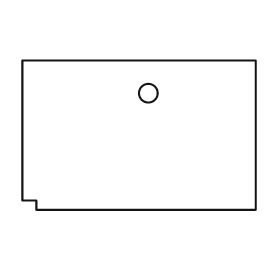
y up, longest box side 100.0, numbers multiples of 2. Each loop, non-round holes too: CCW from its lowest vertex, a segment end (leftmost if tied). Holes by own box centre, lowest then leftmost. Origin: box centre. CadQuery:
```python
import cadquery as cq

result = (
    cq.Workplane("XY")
    .moveTo(-44.0, -32.0)
    .lineTo(50.0, -32.0)
    .lineTo(50.0, 32.0)
    .lineTo(-50.0, 32.0)
    .lineTo(-50.0, -28.0)
    .lineTo(-44.0, -28.0)
    .close()
    .moveTo(4.0, 18.0)
    .circle(4.0)
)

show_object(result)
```